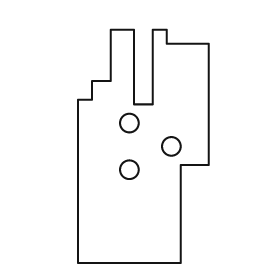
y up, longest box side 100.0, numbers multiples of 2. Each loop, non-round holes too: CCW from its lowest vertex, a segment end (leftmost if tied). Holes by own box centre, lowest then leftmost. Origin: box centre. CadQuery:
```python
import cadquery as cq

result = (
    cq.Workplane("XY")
    .moveTo(-28.0, -50.0)
    .lineTo(16.0, -50.0)
    .lineTo(16.0, -8.0)
    .lineTo(28.0, -8.0)
    .lineTo(28.0, 44.0)
    .lineTo(10.0, 44.0)
    .lineTo(10.0, 50.0)
    .lineTo(4.0, 50.0)
    .lineTo(4.0, 18.0)
    .lineTo(-4.0, 18.0)
    .lineTo(-4.0, 50.0)
    .lineTo(-14.0, 50.0)
    .lineTo(-14.0, 28.0)
    .lineTo(-22.0, 28.0)
    .lineTo(-22.0, 20.0)
    .lineTo(-28.0, 20.0)
    .close()
    .moveTo(-6.0, -10.0)
    .circle(4.0)
    .moveTo(12.0, 0.0)
    .circle(4.0)
    .moveTo(-6.0, 10.0)
    .circle(4.0)
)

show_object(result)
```